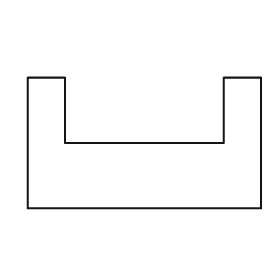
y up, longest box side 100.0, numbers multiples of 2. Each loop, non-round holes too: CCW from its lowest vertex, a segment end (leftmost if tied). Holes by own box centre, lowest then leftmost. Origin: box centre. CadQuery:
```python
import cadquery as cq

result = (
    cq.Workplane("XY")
    .moveTo(-50.0, -28.0)
    .lineTo(50.0, -28.0)
    .lineTo(50.0, 28.0)
    .lineTo(34.0, 28.0)
    .lineTo(34.0, 0.0)
    .lineTo(-34.0, 0.0)
    .lineTo(-34.0, 28.0)
    .lineTo(-50.0, 28.0)
    .close()
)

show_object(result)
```